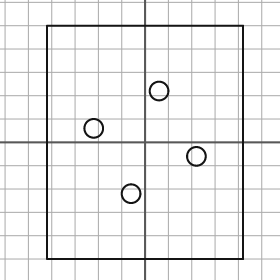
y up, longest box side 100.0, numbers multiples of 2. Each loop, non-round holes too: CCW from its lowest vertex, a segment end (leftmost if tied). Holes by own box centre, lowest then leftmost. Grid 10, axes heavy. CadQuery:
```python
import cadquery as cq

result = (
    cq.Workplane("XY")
    .moveTo(-42.0, -50.0)
    .lineTo(42.0, -50.0)
    .lineTo(42.0, 50.0)
    .lineTo(-42.0, 50.0)
    .close()
    .moveTo(-6.0, -22.0)
    .circle(4.0)
    .moveTo(22.0, -6.0)
    .circle(4.0)
    .moveTo(-22.0, 6.0)
    .circle(4.0)
    .moveTo(6.0, 22.0)
    .circle(4.0)
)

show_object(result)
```